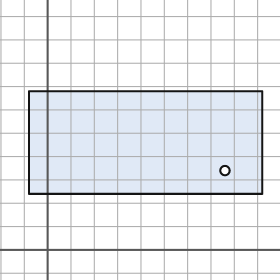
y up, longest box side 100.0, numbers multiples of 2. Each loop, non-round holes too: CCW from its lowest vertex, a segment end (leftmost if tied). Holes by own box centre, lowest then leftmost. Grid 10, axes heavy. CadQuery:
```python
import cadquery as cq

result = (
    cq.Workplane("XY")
    .moveTo(-8.0, 24.0)
    .lineTo(92.0, 24.0)
    .lineTo(92.0, 68.0)
    .lineTo(-8.0, 68.0)
    .close()
    .moveTo(76.0, 34.0)
    .circle(2.0)
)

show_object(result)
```